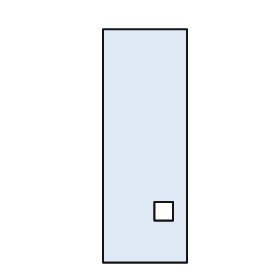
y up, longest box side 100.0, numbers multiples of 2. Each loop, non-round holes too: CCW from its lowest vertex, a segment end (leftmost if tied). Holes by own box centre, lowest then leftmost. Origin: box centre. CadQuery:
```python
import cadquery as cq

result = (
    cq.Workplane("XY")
    .moveTo(-18.0, -50.0)
    .lineTo(18.0, -50.0)
    .lineTo(18.0, 50.0)
    .lineTo(-18.0, 50.0)
    .close()
    .moveTo(4.0, -32.0)
    .lineTo(12.0, -32.0)
    .lineTo(12.0, -24.0)
    .lineTo(4.0, -24.0)
    .close()
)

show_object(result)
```